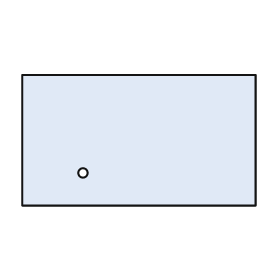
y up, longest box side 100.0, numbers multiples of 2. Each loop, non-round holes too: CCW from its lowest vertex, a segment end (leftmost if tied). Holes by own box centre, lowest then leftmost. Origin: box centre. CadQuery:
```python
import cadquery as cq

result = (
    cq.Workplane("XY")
    .moveTo(-50.0, -28.0)
    .lineTo(50.0, -28.0)
    .lineTo(50.0, 28.0)
    .lineTo(-50.0, 28.0)
    .close()
    .moveTo(-24.0, -14.0)
    .circle(2.0)
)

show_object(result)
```